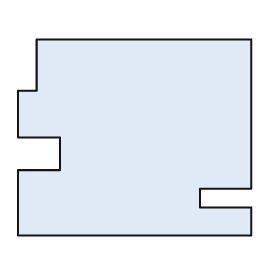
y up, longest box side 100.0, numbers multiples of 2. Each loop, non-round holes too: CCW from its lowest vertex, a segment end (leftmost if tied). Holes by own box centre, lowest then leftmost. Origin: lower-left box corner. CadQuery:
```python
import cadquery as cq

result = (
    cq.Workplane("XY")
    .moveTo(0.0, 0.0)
    .lineTo(100.0, 0.0)
    .lineTo(100.0, 12.0)
    .lineTo(78.0, 12.0)
    .lineTo(78.0, 20.0)
    .lineTo(100.0, 20.0)
    .lineTo(100.0, 84.0)
    .lineTo(8.0, 84.0)
    .lineTo(8.0, 62.0)
    .lineTo(0.0, 62.0)
    .lineTo(0.0, 42.0)
    .lineTo(18.0, 42.0)
    .lineTo(18.0, 28.0)
    .lineTo(0.0, 28.0)
    .close()
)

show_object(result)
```